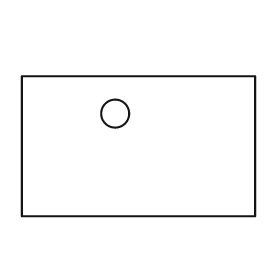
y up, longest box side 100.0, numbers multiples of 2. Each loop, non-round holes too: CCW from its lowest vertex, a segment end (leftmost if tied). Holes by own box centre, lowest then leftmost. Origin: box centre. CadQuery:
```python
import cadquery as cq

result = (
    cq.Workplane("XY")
    .moveTo(-50.0, -30.0)
    .lineTo(50.0, -30.0)
    .lineTo(50.0, 30.0)
    .lineTo(-50.0, 30.0)
    .close()
    .moveTo(-10.0, 14.0)
    .circle(6.0)
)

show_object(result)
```